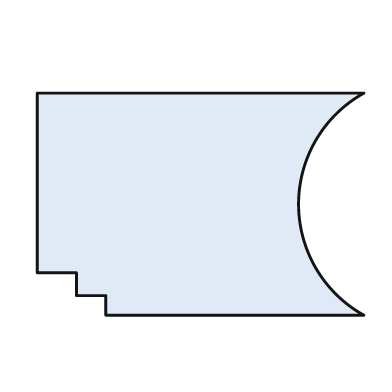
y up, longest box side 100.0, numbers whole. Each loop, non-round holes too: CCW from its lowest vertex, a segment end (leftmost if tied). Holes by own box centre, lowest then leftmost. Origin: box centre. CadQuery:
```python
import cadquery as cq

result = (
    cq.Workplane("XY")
    .moveTo(-29.0, -34.0)
    .lineTo(50.0, -34.0)
    .threePointArc((30.0, 0.0), (50.0, 34.0))
    .lineTo(-50.0, 34.0)
    .lineTo(-50.0, -21.0)
    .lineTo(-38.0, -21.0)
    .lineTo(-38.0, -28.0)
    .lineTo(-29.0, -28.0)
    .close()
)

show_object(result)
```